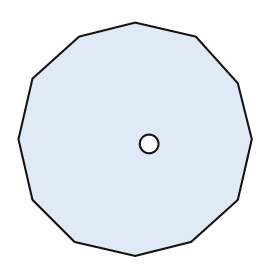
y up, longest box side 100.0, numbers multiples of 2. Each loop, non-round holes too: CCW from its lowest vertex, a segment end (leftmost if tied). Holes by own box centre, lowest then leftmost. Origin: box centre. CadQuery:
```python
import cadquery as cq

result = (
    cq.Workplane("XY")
    .moveTo(0.0, -50.0)
    .lineTo(24.0, -44.0)
    .lineTo(44.0, -26.0)
    .lineTo(50.0, 0.0)
    .lineTo(44.0, 24.0)
    .lineTo(26.0, 44.0)
    .lineTo(0.0, 50.0)
    .lineTo(-24.0, 44.0)
    .lineTo(-44.0, 26.0)
    .lineTo(-50.0, 0.0)
    .lineTo(-44.0, -26.0)
    .lineTo(-26.0, -44.0)
    .close()
    .moveTo(6.0, -2.0)
    .circle(4.0)
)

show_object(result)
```